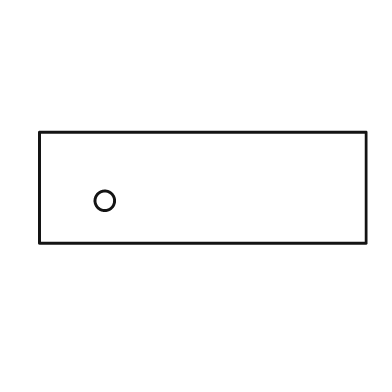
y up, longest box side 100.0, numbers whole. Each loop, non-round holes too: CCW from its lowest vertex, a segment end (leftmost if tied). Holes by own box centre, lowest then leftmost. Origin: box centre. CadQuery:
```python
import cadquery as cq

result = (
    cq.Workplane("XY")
    .moveTo(-50.0, -17.0)
    .lineTo(50.0, -17.0)
    .lineTo(50.0, 17.0)
    .lineTo(-50.0, 17.0)
    .close()
    .moveTo(-30.0, -4.0)
    .circle(3.0)
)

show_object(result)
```